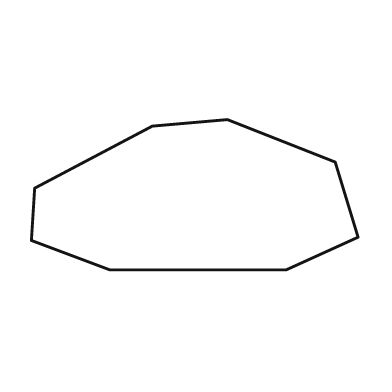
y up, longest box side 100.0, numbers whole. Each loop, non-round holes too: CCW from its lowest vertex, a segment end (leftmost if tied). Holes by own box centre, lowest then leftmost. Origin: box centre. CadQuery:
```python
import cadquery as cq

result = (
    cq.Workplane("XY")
    .moveTo(-26.0, -23.0)
    .lineTo(28.0, -23.0)
    .lineTo(50.0, -13.0)
    .lineTo(43.0, 10.0)
    .lineTo(10.0, 23.0)
    .lineTo(-13.0, 21.0)
    .lineTo(-49.0, 2.0)
    .lineTo(-50.0, -14.0)
    .close()
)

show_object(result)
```